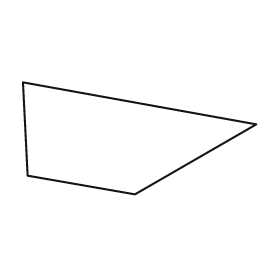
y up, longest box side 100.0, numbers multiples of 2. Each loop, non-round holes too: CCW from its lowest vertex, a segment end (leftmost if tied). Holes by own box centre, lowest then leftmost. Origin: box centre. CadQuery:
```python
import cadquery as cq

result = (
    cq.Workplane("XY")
    .moveTo(-2.0, -24.0)
    .lineTo(50.0, 6.0)
    .lineTo(-50.0, 24.0)
    .lineTo(-48.0, -16.0)
    .close()
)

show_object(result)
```